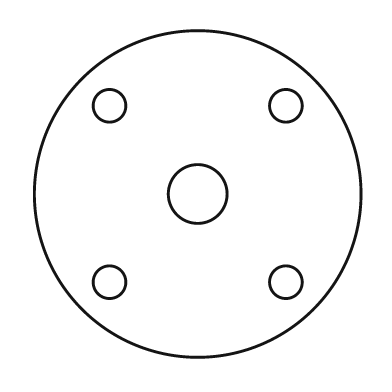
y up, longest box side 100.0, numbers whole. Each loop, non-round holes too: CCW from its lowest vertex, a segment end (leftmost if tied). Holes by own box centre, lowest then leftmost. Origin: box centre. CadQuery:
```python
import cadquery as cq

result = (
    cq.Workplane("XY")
    .moveTo(0.0, 0.0)
    .circle(50.0)
    .moveTo(-27.0, -27.0)
    .circle(5.0)
    .moveTo(27.0, -27.0)
    .circle(5.0)
    .moveTo(0.0, 0.0)
    .circle(9.0)
    .moveTo(-27.0, 27.0)
    .circle(5.0)
    .moveTo(27.0, 27.0)
    .circle(5.0)
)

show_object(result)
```